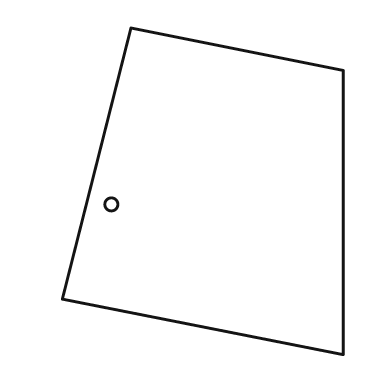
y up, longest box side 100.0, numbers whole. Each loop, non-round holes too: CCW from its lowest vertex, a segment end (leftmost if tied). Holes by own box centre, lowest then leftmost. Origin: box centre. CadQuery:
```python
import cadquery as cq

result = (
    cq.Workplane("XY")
    .moveTo(43.0, -50.0)
    .lineTo(43.0, 37.0)
    .lineTo(-22.0, 50.0)
    .lineTo(-43.0, -33.0)
    .close()
    .moveTo(-28.0, -4.0)
    .circle(2.0)
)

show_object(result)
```